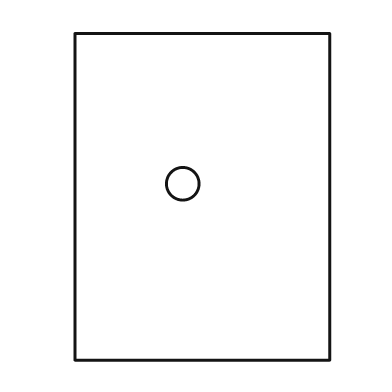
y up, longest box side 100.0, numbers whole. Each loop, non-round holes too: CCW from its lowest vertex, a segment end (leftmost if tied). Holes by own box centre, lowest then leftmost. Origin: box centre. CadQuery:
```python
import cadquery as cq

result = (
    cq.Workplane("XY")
    .moveTo(-39.0, -50.0)
    .lineTo(39.0, -50.0)
    .lineTo(39.0, 50.0)
    .lineTo(-39.0, 50.0)
    .close()
    .moveTo(-6.0, 4.0)
    .circle(5.0)
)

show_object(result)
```